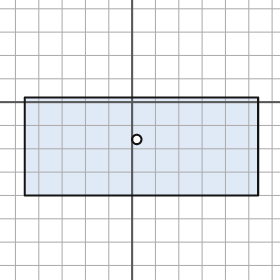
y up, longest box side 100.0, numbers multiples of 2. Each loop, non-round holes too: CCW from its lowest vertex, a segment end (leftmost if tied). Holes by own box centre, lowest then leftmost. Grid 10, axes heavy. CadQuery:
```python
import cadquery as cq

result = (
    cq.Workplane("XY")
    .moveTo(-46.0, -40.0)
    .lineTo(54.0, -40.0)
    .lineTo(54.0, 2.0)
    .lineTo(-46.0, 2.0)
    .close()
    .moveTo(2.0, -16.0)
    .circle(2.0)
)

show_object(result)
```